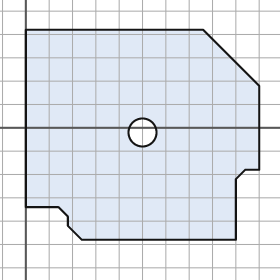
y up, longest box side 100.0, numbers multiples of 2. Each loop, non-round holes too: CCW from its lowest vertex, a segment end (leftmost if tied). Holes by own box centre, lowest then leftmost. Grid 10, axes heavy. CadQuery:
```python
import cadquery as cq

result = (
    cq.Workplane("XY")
    .moveTo(24.0, -48.0)
    .lineTo(90.0, -48.0)
    .lineTo(90.0, -22.0)
    .lineTo(94.0, -18.0)
    .lineTo(100.0, -18.0)
    .lineTo(100.0, 18.0)
    .lineTo(76.0, 42.0)
    .lineTo(0.0, 42.0)
    .lineTo(0.0, -34.0)
    .lineTo(14.0, -34.0)
    .lineTo(18.0, -38.0)
    .lineTo(18.0, -42.0)
    .close()
    .moveTo(50.0, -2.0)
    .circle(6.0)
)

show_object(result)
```